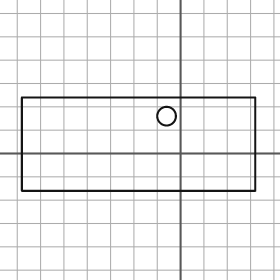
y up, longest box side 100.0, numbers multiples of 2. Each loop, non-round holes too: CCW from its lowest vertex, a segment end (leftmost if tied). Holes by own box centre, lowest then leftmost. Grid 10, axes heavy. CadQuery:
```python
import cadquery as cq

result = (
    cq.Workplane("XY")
    .moveTo(-68.0, -16.0)
    .lineTo(32.0, -16.0)
    .lineTo(32.0, 24.0)
    .lineTo(-68.0, 24.0)
    .close()
    .moveTo(-6.0, 16.0)
    .circle(4.0)
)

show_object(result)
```